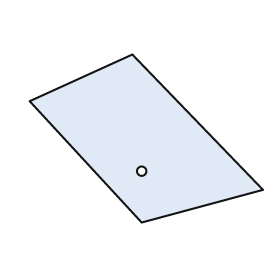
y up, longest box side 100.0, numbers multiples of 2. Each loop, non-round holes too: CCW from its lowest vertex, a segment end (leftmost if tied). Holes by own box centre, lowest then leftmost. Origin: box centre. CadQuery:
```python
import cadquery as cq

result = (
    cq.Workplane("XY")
    .moveTo(-2.0, -36.0)
    .lineTo(50.0, -22.0)
    .lineTo(-6.0, 36.0)
    .lineTo(-50.0, 16.0)
    .close()
    .moveTo(-2.0, -14.0)
    .circle(2.0)
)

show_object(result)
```